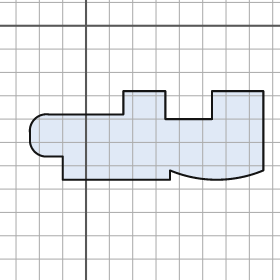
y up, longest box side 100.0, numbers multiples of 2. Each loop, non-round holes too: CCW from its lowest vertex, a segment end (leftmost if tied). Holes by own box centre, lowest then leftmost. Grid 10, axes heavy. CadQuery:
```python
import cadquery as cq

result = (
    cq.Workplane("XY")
    .moveTo(-10.0, -66.0)
    .lineTo(36.0, -66.0)
    .lineTo(36.0, -62.0)
    .threePointArc((56.0, -66.0), (76.0, -62.0))
    .lineTo(76.0, -28.0)
    .lineTo(54.0, -28.0)
    .lineTo(54.0, -40.0)
    .lineTo(34.0, -40.0)
    .lineTo(34.0, -28.0)
    .lineTo(16.0, -28.0)
    .lineTo(16.0, -38.0)
    .lineTo(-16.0, -38.0)
    .threePointArc((-22.0, -40.0), (-24.0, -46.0))
    .lineTo(-24.0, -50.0)
    .threePointArc((-22.0, -54.0), (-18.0, -56.0))
    .lineTo(-10.0, -56.0)
    .close()
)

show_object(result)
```